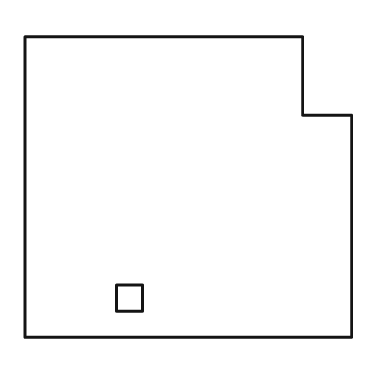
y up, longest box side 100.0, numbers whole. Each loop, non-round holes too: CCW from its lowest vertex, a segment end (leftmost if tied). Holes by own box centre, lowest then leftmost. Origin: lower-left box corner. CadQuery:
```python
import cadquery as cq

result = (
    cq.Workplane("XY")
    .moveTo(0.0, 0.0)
    .lineTo(100.0, 0.0)
    .lineTo(100.0, 68.0)
    .lineTo(85.0, 68.0)
    .lineTo(85.0, 92.0)
    .lineTo(0.0, 92.0)
    .close()
    .moveTo(28.0, 8.0)
    .lineTo(36.0, 8.0)
    .lineTo(36.0, 16.0)
    .lineTo(28.0, 16.0)
    .close()
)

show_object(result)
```